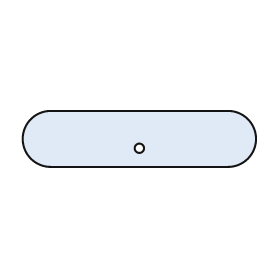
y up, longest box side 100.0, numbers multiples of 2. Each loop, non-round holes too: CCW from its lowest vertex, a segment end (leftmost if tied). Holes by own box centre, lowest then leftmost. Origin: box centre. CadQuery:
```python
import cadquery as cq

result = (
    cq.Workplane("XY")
    .moveTo(-38.0, -12.0)
    .lineTo(38.0, -12.0)
    .threePointArc((50.0, 0.0), (38.0, 12.0))
    .lineTo(-38.0, 12.0)
    .threePointArc((-50.0, 0.0), (-38.0, -12.0))
    .close()
    .moveTo(0.0, -4.0)
    .circle(2.0)
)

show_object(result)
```